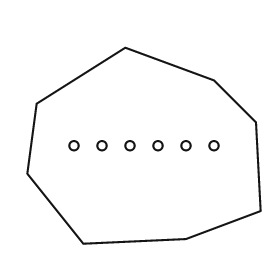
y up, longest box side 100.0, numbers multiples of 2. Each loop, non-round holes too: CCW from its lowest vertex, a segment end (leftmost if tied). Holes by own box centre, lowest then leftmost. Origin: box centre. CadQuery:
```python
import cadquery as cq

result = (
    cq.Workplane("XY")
    .moveTo(-26.0, -42.0)
    .lineTo(18.0, -40.0)
    .lineTo(50.0, -28.0)
    .lineTo(48.0, 10.0)
    .lineTo(30.0, 28.0)
    .lineTo(-8.0, 42.0)
    .lineTo(-46.0, 18.0)
    .lineTo(-50.0, -12.0)
    .close()
    .moveTo(-30.0, 0.0)
    .circle(2.0)
    .moveTo(-18.0, 0.0)
    .circle(2.0)
    .moveTo(-6.0, 0.0)
    .circle(2.0)
    .moveTo(6.0, 0.0)
    .circle(2.0)
    .moveTo(18.0, 0.0)
    .circle(2.0)
    .moveTo(30.0, 0.0)
    .circle(2.0)
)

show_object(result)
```